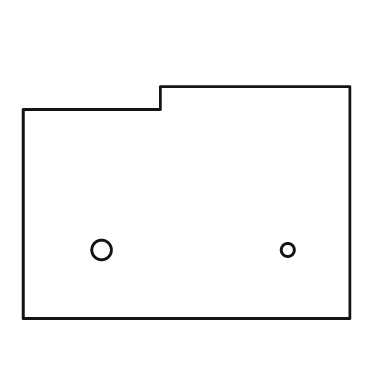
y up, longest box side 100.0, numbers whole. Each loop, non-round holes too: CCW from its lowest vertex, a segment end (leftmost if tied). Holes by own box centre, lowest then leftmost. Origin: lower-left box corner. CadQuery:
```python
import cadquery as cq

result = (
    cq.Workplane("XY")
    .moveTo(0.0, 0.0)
    .lineTo(100.0, 0.0)
    .lineTo(100.0, 71.0)
    .lineTo(42.0, 71.0)
    .lineTo(42.0, 64.0)
    .lineTo(0.0, 64.0)
    .close()
    .moveTo(24.0, 21.0)
    .circle(3.0)
    .moveTo(81.0, 21.0)
    .circle(2.0)
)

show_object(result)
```